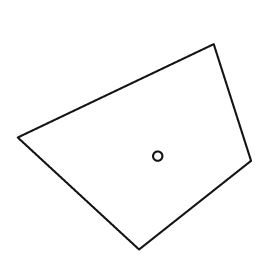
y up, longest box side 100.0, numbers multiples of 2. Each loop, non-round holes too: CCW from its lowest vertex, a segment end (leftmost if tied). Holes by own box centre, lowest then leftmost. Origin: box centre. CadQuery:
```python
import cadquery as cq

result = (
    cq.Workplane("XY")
    .moveTo(2.0, -44.0)
    .lineTo(50.0, -6.0)
    .lineTo(34.0, 44.0)
    .lineTo(-50.0, 4.0)
    .close()
    .moveTo(10.0, -4.0)
    .circle(2.0)
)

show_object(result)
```